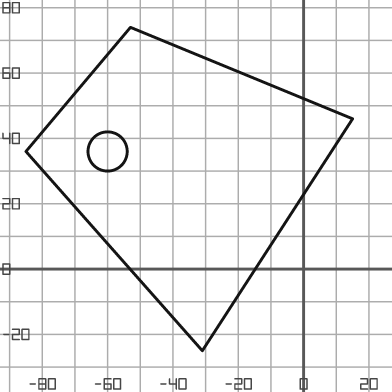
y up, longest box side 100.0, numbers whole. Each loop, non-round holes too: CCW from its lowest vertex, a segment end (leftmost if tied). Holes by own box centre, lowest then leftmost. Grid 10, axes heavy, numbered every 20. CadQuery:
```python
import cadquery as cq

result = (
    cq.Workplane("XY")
    .moveTo(-31.0, -25.0)
    .lineTo(15.0, 46.0)
    .lineTo(-53.0, 74.0)
    .lineTo(-85.0, 36.0)
    .close()
    .moveTo(-60.0, 36.0)
    .circle(6.0)
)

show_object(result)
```